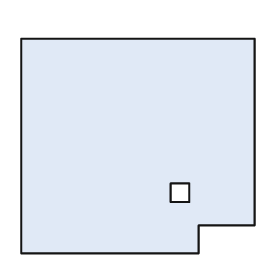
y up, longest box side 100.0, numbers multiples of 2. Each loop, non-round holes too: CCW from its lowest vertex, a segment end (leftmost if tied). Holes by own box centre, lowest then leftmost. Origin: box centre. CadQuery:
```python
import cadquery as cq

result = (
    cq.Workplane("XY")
    .moveTo(-50.0, -46.0)
    .lineTo(26.0, -46.0)
    .lineTo(26.0, -34.0)
    .lineTo(50.0, -34.0)
    .lineTo(50.0, 46.0)
    .lineTo(-50.0, 46.0)
    .close()
    .moveTo(14.0, -24.0)
    .lineTo(22.0, -24.0)
    .lineTo(22.0, -16.0)
    .lineTo(14.0, -16.0)
    .close()
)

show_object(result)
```